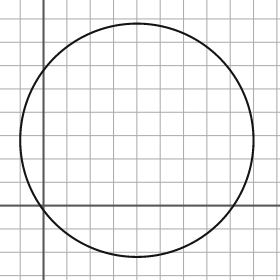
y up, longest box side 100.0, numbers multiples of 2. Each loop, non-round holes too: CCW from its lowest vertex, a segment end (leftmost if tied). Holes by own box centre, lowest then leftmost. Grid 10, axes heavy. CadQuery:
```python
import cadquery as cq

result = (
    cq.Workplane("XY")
    .moveTo(40.0, 28.0)
    .circle(50.0)
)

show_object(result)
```